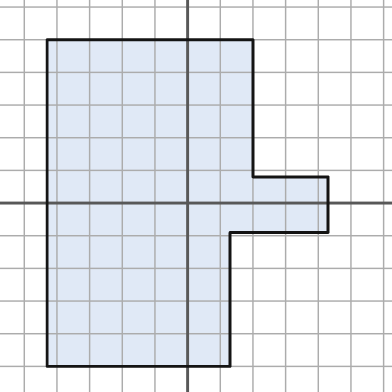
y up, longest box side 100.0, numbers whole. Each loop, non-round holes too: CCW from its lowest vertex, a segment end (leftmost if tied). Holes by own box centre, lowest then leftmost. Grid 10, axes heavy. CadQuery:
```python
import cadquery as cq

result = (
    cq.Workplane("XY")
    .moveTo(-43.0, -50.0)
    .lineTo(13.0, -50.0)
    .lineTo(13.0, -9.0)
    .lineTo(43.0, -9.0)
    .lineTo(43.0, 8.0)
    .lineTo(20.0, 8.0)
    .lineTo(20.0, 50.0)
    .lineTo(-43.0, 50.0)
    .close()
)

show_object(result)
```